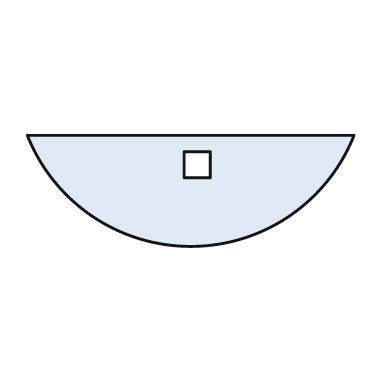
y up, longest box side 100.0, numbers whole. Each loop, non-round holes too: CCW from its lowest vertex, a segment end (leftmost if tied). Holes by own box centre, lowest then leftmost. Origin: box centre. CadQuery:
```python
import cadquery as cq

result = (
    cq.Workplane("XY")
    .moveTo(-50.0, 17.0)
    .threePointArc((0.0, -17.0), (50.0, 17.0))
    .close()
    .moveTo(-2.0, 4.0)
    .lineTo(6.0, 4.0)
    .lineTo(6.0, 12.0)
    .lineTo(-2.0, 12.0)
    .close()
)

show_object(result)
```